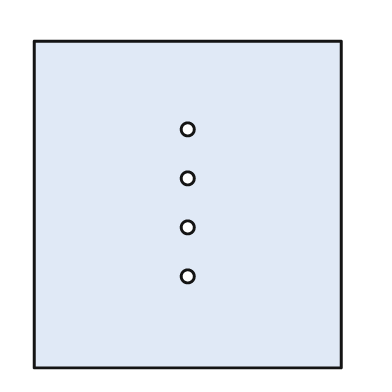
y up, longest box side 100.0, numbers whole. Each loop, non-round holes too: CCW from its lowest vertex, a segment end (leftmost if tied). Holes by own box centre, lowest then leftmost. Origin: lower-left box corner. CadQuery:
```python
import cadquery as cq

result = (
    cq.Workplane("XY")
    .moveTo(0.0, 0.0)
    .lineTo(94.0, 0.0)
    .lineTo(94.0, 100.0)
    .lineTo(0.0, 100.0)
    .close()
    .moveTo(47.0, 28.0)
    .circle(2.0)
    .moveTo(47.0, 43.0)
    .circle(2.0)
    .moveTo(47.0, 58.0)
    .circle(2.0)
    .moveTo(47.0, 73.0)
    .circle(2.0)
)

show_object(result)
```